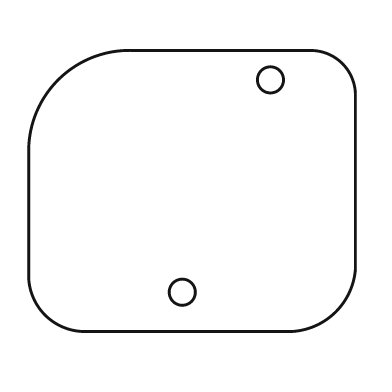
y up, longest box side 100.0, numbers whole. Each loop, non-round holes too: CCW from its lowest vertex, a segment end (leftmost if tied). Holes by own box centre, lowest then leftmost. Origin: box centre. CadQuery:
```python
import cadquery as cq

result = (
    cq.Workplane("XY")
    .moveTo(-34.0, -43.0)
    .lineTo(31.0, -43.0)
    .threePointArc((44.0, -37.0), (50.0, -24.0))
    .lineTo(50.0, 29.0)
    .threePointArc((46.0, 39.0), (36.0, 43.0))
    .lineTo(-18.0, 43.0)
    .threePointArc((-41.0, 34.0), (-50.0, 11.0))
    .lineTo(-50.0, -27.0)
    .threePointArc((-45.0, -38.0), (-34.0, -43.0))
    .close()
    .moveTo(-3.0, -31.0)
    .circle(4.0)
    .moveTo(24.0, 34.0)
    .circle(4.0)
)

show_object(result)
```